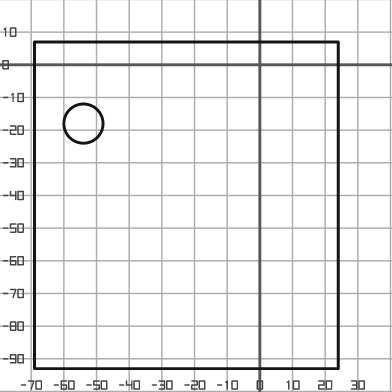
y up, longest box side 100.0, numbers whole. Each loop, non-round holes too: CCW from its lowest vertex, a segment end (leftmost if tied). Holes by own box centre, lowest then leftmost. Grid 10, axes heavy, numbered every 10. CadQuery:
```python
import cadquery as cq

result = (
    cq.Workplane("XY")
    .moveTo(-69.0, -93.0)
    .lineTo(24.0, -93.0)
    .lineTo(24.0, 7.0)
    .lineTo(-69.0, 7.0)
    .close()
    .moveTo(-54.0, -18.0)
    .circle(6.0)
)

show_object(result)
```